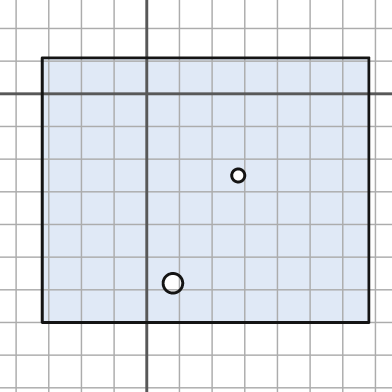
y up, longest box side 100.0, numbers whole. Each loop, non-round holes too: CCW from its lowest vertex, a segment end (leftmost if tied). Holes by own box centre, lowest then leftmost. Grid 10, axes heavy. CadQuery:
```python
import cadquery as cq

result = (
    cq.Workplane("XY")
    .moveTo(-32.0, -70.0)
    .lineTo(68.0, -70.0)
    .lineTo(68.0, 11.0)
    .lineTo(-32.0, 11.0)
    .close()
    .moveTo(8.0, -58.0)
    .circle(3.0)
    .moveTo(28.0, -25.0)
    .circle(2.0)
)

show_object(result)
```